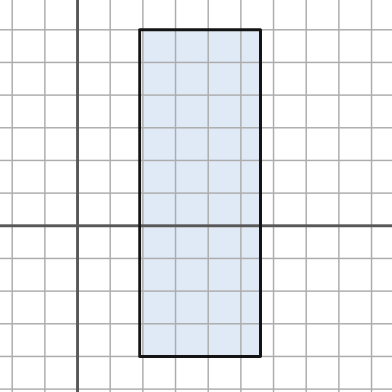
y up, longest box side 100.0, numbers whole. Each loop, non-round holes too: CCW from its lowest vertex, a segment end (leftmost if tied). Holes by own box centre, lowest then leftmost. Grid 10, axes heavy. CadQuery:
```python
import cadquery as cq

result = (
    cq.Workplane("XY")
    .moveTo(19.0, -40.0)
    .lineTo(56.0, -40.0)
    .lineTo(56.0, 60.0)
    .lineTo(19.0, 60.0)
    .close()
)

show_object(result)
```